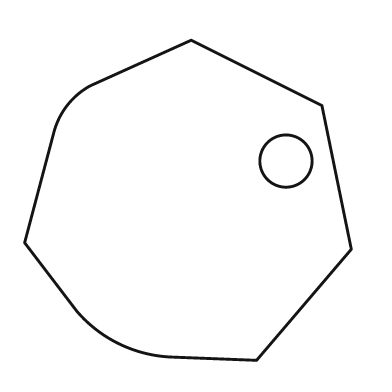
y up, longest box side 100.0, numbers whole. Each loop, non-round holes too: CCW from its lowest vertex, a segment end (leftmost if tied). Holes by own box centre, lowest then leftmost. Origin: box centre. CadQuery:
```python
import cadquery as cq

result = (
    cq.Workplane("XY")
    .moveTo(21.0, -49.0)
    .lineTo(50.0, -15.0)
    .lineTo(41.0, 29.0)
    .lineTo(1.0, 49.0)
    .lineTo(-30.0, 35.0)
    .threePointArc((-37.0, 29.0), (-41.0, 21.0))
    .lineTo(-50.0, -13.0)
    .lineTo(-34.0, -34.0)
    .threePointArc((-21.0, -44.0), (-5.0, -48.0))
    .close()
    .moveTo(30.0, 12.0)
    .circle(8.0)
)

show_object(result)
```